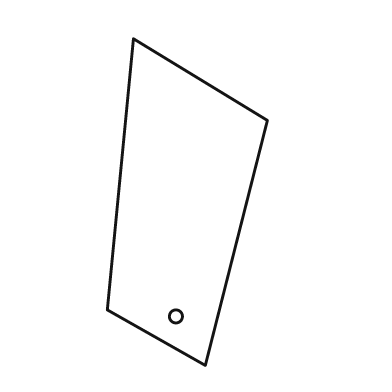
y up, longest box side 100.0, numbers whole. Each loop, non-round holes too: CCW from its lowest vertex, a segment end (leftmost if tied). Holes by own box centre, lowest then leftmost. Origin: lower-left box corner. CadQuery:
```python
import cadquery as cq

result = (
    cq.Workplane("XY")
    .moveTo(30.0, 0.0)
    .lineTo(49.0, 75.0)
    .lineTo(8.0, 100.0)
    .lineTo(0.0, 17.0)
    .close()
    .moveTo(21.0, 15.0)
    .circle(2.0)
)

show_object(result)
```